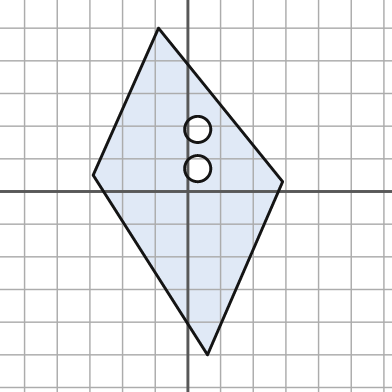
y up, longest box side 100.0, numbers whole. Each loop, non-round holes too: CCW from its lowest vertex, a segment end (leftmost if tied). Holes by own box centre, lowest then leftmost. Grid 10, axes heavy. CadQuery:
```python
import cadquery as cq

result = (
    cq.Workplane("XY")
    .moveTo(6.0, -50.0)
    .lineTo(29.0, 3.0)
    .lineTo(-9.0, 50.0)
    .lineTo(-29.0, 5.0)
    .close()
    .moveTo(3.0, 7.0)
    .circle(4.0)
    .moveTo(3.0, 19.0)
    .circle(4.0)
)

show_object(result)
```